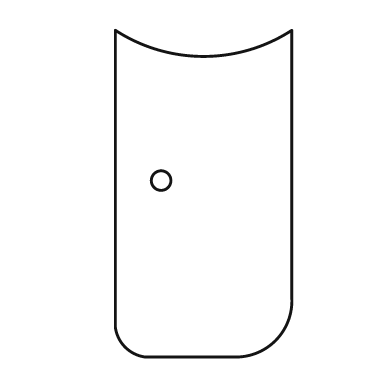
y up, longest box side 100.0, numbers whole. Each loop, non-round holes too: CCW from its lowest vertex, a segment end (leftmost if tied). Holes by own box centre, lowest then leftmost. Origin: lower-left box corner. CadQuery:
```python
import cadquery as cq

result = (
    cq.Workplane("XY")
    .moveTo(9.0, 0.0)
    .lineTo(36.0, 0.0)
    .threePointArc((49.0, 5.0), (54.0, 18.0))
    .lineTo(54.0, 100.0)
    .threePointArc((27.0, 92.0), (0.0, 100.0))
    .lineTo(0.0, 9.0)
    .threePointArc((3.0, 3.0), (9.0, 0.0))
    .close()
    .moveTo(14.0, 54.0)
    .circle(3.0)
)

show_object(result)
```